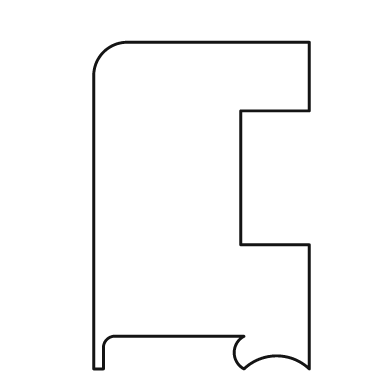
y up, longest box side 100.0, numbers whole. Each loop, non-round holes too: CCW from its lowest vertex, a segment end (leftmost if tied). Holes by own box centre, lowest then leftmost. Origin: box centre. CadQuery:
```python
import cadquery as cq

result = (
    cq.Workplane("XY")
    .moveTo(-33.0, -50.0)
    .lineTo(-30.0, -50.0)
    .lineTo(-30.0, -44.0)
    .threePointArc((-29.0, -41.0), (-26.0, -40.0))
    .lineTo(13.0, -40.0)
    .threePointArc((10.0, -45.0), (13.0, -50.0))
    .threePointArc((23.0, -46.0), (33.0, -50.0))
    .lineTo(33.0, -12.0)
    .lineTo(12.0, -12.0)
    .lineTo(12.0, 29.0)
    .lineTo(33.0, 29.0)
    .lineTo(33.0, 50.0)
    .lineTo(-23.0, 50.0)
    .threePointArc((-30.0, 47.0), (-33.0, 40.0))
    .close()
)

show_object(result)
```